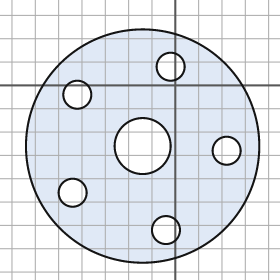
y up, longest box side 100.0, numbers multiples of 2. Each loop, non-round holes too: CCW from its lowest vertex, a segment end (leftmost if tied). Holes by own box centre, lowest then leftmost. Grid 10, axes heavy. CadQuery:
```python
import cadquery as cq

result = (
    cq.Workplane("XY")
    .moveTo(-14.0, -26.0)
    .circle(50.0)
    .moveTo(-4.0, -62.0)
    .circle(6.0)
    .moveTo(-44.0, -46.0)
    .circle(6.0)
    .moveTo(22.0, -28.0)
    .circle(6.0)
    .moveTo(-14.0, -26.0)
    .circle(12.0)
    .moveTo(-42.0, -4.0)
    .circle(6.0)
    .moveTo(-2.0, 8.0)
    .circle(6.0)
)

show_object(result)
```